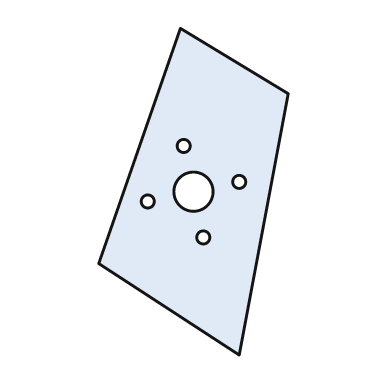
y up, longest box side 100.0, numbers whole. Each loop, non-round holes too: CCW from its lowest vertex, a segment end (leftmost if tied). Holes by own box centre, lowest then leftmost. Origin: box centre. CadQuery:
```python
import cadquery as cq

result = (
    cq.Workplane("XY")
    .moveTo(14.0, -50.0)
    .lineTo(29.0, 30.0)
    .lineTo(-4.0, 50.0)
    .lineTo(-29.0, -22.0)
    .close()
    .moveTo(3.0, -14.0)
    .circle(2.0)
    .moveTo(-14.0, -3.0)
    .circle(2.0)
    .moveTo(0.0, 0.0)
    .circle(6.0)
    .moveTo(14.0, 3.0)
    .circle(2.0)
    .moveTo(-3.0, 14.0)
    .circle(2.0)
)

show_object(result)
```